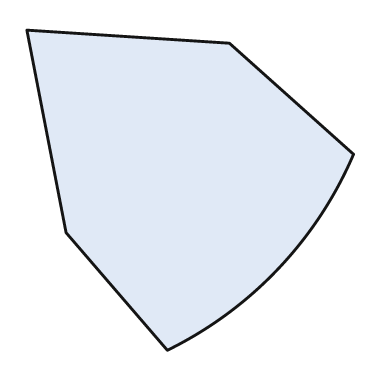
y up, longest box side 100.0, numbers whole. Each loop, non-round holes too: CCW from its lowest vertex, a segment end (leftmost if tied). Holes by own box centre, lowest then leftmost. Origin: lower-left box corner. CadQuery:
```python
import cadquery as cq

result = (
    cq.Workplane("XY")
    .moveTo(43.0, 0.0)
    .threePointArc((77.0, 25.0), (100.0, 60.0))
    .lineTo(62.0, 94.0)
    .lineTo(0.0, 98.0)
    .lineTo(12.0, 36.0)
    .close()
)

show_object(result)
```